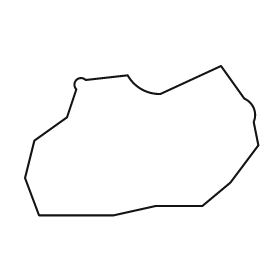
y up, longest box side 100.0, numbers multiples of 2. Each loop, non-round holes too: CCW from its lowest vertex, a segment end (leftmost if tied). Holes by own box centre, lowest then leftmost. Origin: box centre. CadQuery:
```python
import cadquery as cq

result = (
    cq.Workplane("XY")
    .moveTo(-44.0, -32.0)
    .lineTo(-12.0, -32.0)
    .lineTo(6.0, -28.0)
    .lineTo(26.0, -28.0)
    .lineTo(38.0, -18.0)
    .lineTo(50.0, -2.0)
    .lineTo(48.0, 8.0)
    .threePointArc((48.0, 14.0), (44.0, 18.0))
    .lineTo(34.0, 32.0)
    .lineTo(8.0, 20.0)
    .threePointArc((0.0, 22.0), (-6.0, 28.0))
    .lineTo(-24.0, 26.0)
    .threePointArc((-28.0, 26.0), (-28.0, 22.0))
    .lineTo(-32.0, 10.0)
    .lineTo(-46.0, 0.0)
    .lineTo(-50.0, -16.0)
    .close()
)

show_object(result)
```